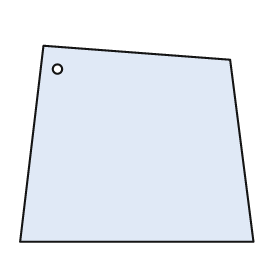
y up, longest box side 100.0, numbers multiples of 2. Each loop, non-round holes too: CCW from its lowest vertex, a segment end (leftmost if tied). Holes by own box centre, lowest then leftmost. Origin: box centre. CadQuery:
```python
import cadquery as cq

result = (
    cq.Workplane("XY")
    .moveTo(-50.0, -42.0)
    .lineTo(50.0, -42.0)
    .lineTo(40.0, 36.0)
    .lineTo(-40.0, 42.0)
    .close()
    .moveTo(-34.0, 32.0)
    .circle(2.0)
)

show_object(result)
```